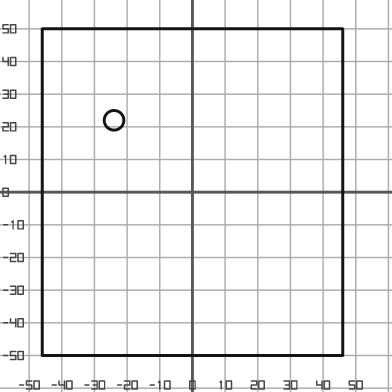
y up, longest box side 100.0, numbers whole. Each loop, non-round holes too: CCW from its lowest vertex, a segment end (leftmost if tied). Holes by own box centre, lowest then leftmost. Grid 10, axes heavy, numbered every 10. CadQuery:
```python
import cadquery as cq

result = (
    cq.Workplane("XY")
    .moveTo(-46.0, -50.0)
    .lineTo(46.0, -50.0)
    .lineTo(46.0, 50.0)
    .lineTo(-46.0, 50.0)
    .close()
    .moveTo(-24.0, 22.0)
    .circle(3.0)
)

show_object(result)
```